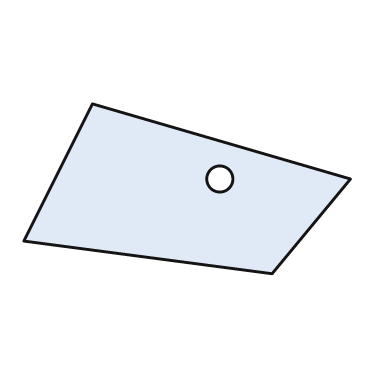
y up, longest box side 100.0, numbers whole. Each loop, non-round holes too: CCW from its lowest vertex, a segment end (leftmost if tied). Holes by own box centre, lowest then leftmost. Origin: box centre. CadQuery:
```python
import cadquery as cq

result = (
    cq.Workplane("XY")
    .moveTo(26.0, -26.0)
    .lineTo(50.0, 3.0)
    .lineTo(-29.0, 26.0)
    .lineTo(-50.0, -16.0)
    .close()
    .moveTo(10.0, 3.0)
    .circle(4.0)
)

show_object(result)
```